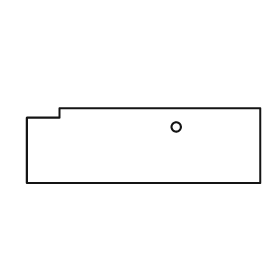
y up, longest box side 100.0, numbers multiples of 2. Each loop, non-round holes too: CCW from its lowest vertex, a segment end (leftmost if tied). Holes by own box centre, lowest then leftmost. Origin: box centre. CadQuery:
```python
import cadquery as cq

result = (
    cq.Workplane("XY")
    .moveTo(-50.0, -16.0)
    .lineTo(50.0, -16.0)
    .lineTo(50.0, 16.0)
    .lineTo(-36.0, 16.0)
    .lineTo(-36.0, 12.0)
    .lineTo(-50.0, 12.0)
    .close()
    .moveTo(14.0, 8.0)
    .circle(2.0)
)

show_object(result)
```